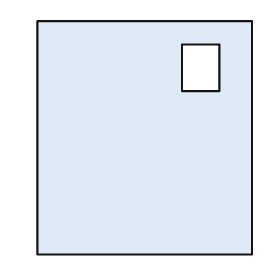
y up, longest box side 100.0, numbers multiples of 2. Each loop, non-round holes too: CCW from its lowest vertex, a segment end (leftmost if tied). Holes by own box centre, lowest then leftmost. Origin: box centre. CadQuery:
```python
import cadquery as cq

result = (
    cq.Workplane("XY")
    .moveTo(-46.0, -50.0)
    .lineTo(46.0, -50.0)
    .lineTo(46.0, 50.0)
    .lineTo(-46.0, 50.0)
    .close()
    .moveTo(16.0, 20.0)
    .lineTo(32.0, 20.0)
    .lineTo(32.0, 40.0)
    .lineTo(16.0, 40.0)
    .close()
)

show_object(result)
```